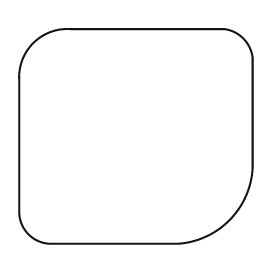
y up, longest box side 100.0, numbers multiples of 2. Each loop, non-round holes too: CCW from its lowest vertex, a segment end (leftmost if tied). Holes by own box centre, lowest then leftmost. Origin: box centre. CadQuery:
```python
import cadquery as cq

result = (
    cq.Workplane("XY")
    .moveTo(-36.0, -46.0)
    .lineTo(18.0, -46.0)
    .threePointArc((40.0, -36.0), (50.0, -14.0))
    .lineTo(50.0, 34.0)
    .threePointArc((46.0, 42.0), (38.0, 46.0))
    .lineTo(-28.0, 46.0)
    .threePointArc((-44.0, 40.0), (-50.0, 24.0))
    .lineTo(-50.0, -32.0)
    .threePointArc((-46.0, -42.0), (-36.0, -46.0))
    .close()
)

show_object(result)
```